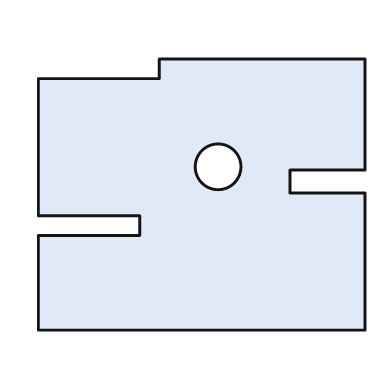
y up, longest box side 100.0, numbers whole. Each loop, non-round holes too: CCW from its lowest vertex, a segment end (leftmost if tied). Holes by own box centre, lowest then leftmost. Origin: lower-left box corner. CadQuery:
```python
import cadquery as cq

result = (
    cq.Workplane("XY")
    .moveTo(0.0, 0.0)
    .lineTo(100.0, 0.0)
    .lineTo(100.0, 42.0)
    .lineTo(77.0, 42.0)
    .lineTo(77.0, 49.0)
    .lineTo(100.0, 49.0)
    .lineTo(100.0, 83.0)
    .lineTo(37.0, 83.0)
    .lineTo(37.0, 77.0)
    .lineTo(0.0, 77.0)
    .lineTo(0.0, 35.0)
    .lineTo(31.0, 35.0)
    .lineTo(31.0, 29.0)
    .lineTo(0.0, 29.0)
    .close()
    .moveTo(55.0, 50.0)
    .circle(7.0)
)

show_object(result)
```